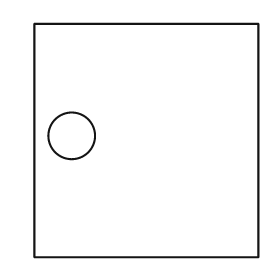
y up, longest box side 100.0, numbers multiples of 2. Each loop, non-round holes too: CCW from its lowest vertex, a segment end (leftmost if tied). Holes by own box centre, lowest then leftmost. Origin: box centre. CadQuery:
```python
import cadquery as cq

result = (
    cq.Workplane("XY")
    .moveTo(-48.0, -50.0)
    .lineTo(48.0, -50.0)
    .lineTo(48.0, 50.0)
    .lineTo(-48.0, 50.0)
    .close()
    .moveTo(-32.0, 2.0)
    .circle(10.0)
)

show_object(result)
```